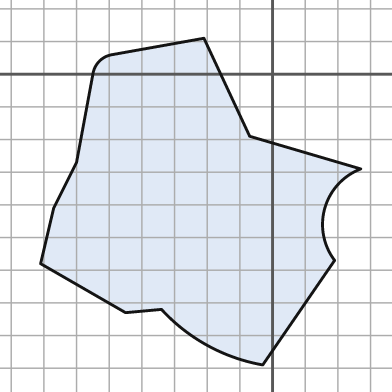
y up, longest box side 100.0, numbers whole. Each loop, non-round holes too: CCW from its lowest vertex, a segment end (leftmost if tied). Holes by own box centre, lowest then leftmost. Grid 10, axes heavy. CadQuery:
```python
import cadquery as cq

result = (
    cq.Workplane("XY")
    .moveTo(-3.0, -89.0)
    .lineTo(19.0, -57.0)
    .threePointArc((16.0, -41.0), (27.0, -29.0))
    .lineTo(-7.0, -19.0)
    .lineTo(-21.0, 11.0)
    .lineTo(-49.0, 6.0)
    .threePointArc((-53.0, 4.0), (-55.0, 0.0))
    .lineTo(-60.0, -27.0)
    .lineTo(-67.0, -41.0)
    .lineTo(-71.0, -58.0)
    .lineTo(-45.0, -73.0)
    .lineTo(-34.0, -72.0)
    .threePointArc((-20.0, -83.0), (-3.0, -89.0))
    .close()
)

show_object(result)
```